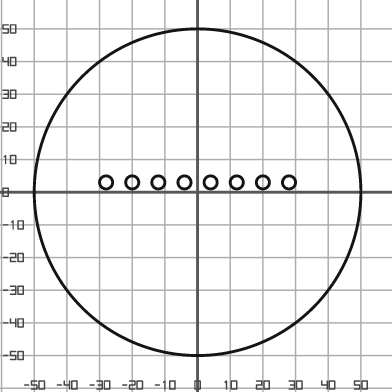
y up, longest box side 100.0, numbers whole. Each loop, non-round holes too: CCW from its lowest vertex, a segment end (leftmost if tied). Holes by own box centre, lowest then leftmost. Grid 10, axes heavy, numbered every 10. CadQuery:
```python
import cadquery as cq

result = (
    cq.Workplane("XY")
    .moveTo(0.0, 0.0)
    .circle(50.0)
    .moveTo(-28.0, 3.0)
    .circle(2.0)
    .moveTo(-20.0, 3.0)
    .circle(2.0)
    .moveTo(-12.0, 3.0)
    .circle(2.0)
    .moveTo(-4.0, 3.0)
    .circle(2.0)
    .moveTo(4.0, 3.0)
    .circle(2.0)
    .moveTo(12.0, 3.0)
    .circle(2.0)
    .moveTo(20.0, 3.0)
    .circle(2.0)
    .moveTo(28.0, 3.0)
    .circle(2.0)
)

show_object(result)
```